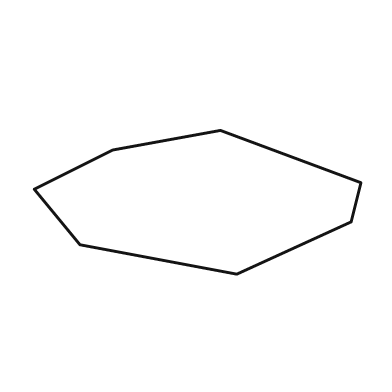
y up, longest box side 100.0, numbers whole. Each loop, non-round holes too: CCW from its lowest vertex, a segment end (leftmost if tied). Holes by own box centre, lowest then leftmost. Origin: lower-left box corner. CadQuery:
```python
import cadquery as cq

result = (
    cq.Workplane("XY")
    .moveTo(62.0, 0.0)
    .lineTo(97.0, 16.0)
    .lineTo(100.0, 28.0)
    .lineTo(57.0, 44.0)
    .lineTo(24.0, 38.0)
    .lineTo(0.0, 26.0)
    .lineTo(14.0, 9.0)
    .close()
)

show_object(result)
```